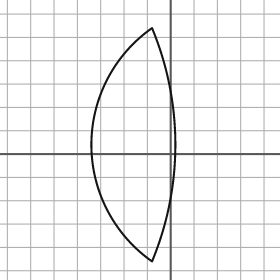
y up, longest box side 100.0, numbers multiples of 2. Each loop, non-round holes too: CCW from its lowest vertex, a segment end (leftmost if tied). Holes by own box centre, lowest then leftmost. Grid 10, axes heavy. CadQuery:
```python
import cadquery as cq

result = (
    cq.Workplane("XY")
    .moveTo(-8.0, -46.0)
    .threePointArc((2.0, 4.0), (-8.0, 54.0))
    .threePointArc((-34.0, 4.0), (-8.0, -46.0))
    .close()
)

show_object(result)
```